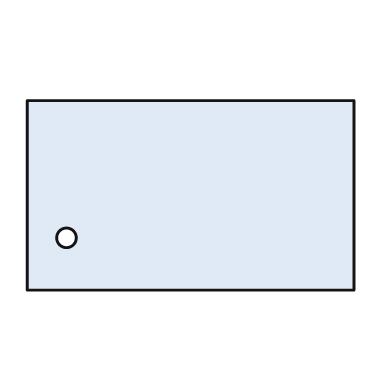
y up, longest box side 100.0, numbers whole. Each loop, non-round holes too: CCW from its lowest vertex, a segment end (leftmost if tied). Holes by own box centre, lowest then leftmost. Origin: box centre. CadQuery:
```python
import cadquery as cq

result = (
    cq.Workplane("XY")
    .moveTo(-50.0, -29.0)
    .lineTo(50.0, -29.0)
    .lineTo(50.0, 29.0)
    .lineTo(-50.0, 29.0)
    .close()
    .moveTo(-38.0, -13.0)
    .circle(3.0)
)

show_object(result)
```